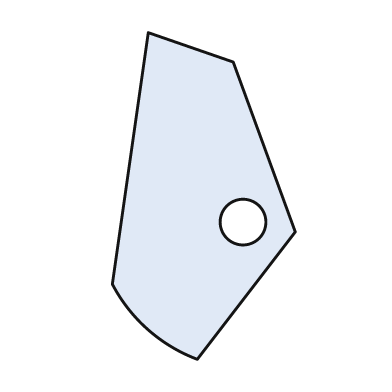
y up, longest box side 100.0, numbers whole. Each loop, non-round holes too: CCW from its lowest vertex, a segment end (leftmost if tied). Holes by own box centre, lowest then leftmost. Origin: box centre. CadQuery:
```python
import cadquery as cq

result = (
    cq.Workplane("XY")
    .moveTo(-2.0, -50.0)
    .lineTo(28.0, -11.0)
    .lineTo(9.0, 41.0)
    .lineTo(-17.0, 50.0)
    .lineTo(-28.0, -27.0)
    .threePointArc((-17.0, -41.0), (-2.0, -50.0))
    .close()
    .moveTo(12.0, -8.0)
    .circle(7.0)
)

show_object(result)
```